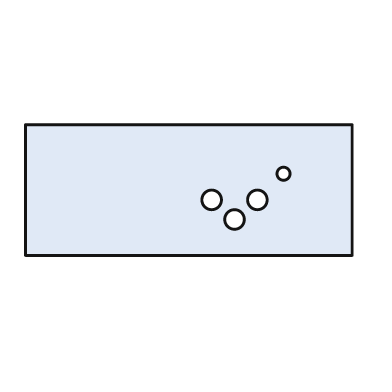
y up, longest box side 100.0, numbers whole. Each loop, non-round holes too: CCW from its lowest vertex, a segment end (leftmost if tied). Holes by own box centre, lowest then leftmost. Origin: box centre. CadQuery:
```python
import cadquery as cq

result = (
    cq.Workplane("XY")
    .moveTo(-50.0, -20.0)
    .lineTo(50.0, -20.0)
    .lineTo(50.0, 20.0)
    .lineTo(-50.0, 20.0)
    .close()
    .moveTo(14.0, -9.0)
    .circle(3.0)
    .moveTo(7.0, -3.0)
    .circle(3.0)
    .moveTo(21.0, -3.0)
    .circle(3.0)
    .moveTo(29.0, 5.0)
    .circle(2.0)
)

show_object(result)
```